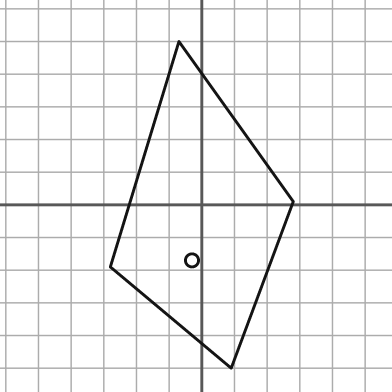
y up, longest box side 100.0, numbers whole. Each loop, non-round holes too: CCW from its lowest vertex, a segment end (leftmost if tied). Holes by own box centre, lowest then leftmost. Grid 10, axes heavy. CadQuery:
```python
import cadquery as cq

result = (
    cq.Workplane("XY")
    .moveTo(9.0, -50.0)
    .lineTo(28.0, 1.0)
    .lineTo(-7.0, 50.0)
    .lineTo(-28.0, -19.0)
    .close()
    .moveTo(-3.0, -17.0)
    .circle(2.0)
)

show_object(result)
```